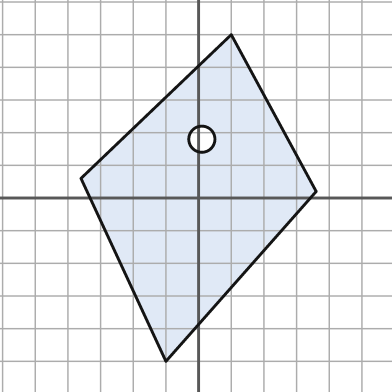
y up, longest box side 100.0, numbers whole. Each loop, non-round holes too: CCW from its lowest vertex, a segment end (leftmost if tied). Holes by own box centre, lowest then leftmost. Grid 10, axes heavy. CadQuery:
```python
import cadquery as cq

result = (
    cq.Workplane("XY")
    .moveTo(-10.0, -50.0)
    .lineTo(36.0, 2.0)
    .lineTo(10.0, 50.0)
    .lineTo(-36.0, 6.0)
    .close()
    .moveTo(1.0, 18.0)
    .circle(4.0)
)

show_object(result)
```